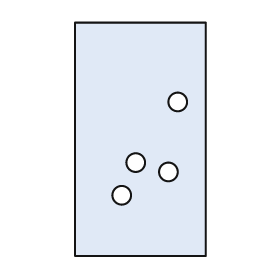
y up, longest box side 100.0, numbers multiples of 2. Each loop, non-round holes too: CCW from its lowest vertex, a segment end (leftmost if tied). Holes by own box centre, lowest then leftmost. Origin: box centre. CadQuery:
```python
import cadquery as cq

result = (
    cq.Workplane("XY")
    .moveTo(-28.0, -50.0)
    .lineTo(28.0, -50.0)
    .lineTo(28.0, 50.0)
    .lineTo(-28.0, 50.0)
    .close()
    .moveTo(-8.0, -24.0)
    .circle(4.0)
    .moveTo(12.0, -14.0)
    .circle(4.0)
    .moveTo(-2.0, -10.0)
    .circle(4.0)
    .moveTo(16.0, 16.0)
    .circle(4.0)
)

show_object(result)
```